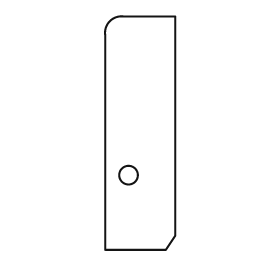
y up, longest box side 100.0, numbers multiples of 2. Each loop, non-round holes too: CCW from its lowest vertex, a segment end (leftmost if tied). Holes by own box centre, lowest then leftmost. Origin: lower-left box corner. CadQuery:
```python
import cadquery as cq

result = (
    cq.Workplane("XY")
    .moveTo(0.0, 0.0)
    .lineTo(26.0, 0.0)
    .lineTo(30.0, 6.0)
    .lineTo(30.0, 100.0)
    .lineTo(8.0, 100.0)
    .threePointArc((2.0, 98.0), (0.0, 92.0))
    .close()
    .moveTo(10.0, 32.0)
    .circle(4.0)
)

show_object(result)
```